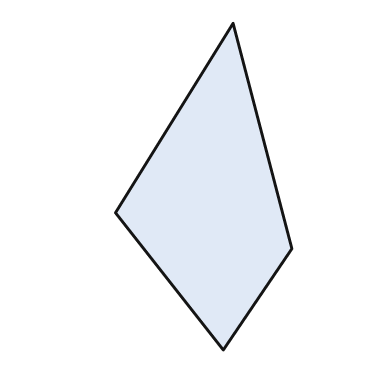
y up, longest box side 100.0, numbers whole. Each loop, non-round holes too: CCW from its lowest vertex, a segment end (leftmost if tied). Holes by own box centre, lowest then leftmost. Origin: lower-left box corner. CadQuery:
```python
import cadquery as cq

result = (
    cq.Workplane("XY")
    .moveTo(33.0, 0.0)
    .lineTo(54.0, 31.0)
    .lineTo(36.0, 100.0)
    .lineTo(0.0, 42.0)
    .close()
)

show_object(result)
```